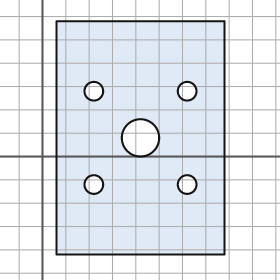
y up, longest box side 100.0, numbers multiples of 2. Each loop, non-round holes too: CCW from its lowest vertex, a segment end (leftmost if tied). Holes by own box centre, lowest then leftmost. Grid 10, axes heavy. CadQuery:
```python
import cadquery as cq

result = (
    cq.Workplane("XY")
    .moveTo(6.0, -42.0)
    .lineTo(78.0, -42.0)
    .lineTo(78.0, 58.0)
    .lineTo(6.0, 58.0)
    .close()
    .moveTo(22.0, -12.0)
    .circle(4.0)
    .moveTo(62.0, -12.0)
    .circle(4.0)
    .moveTo(42.0, 8.0)
    .circle(8.0)
    .moveTo(22.0, 28.0)
    .circle(4.0)
    .moveTo(62.0, 28.0)
    .circle(4.0)
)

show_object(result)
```